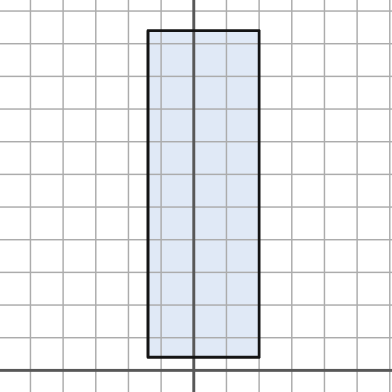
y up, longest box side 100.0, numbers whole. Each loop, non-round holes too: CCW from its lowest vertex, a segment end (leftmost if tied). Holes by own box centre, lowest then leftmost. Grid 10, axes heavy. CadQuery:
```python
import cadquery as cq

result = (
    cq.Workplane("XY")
    .moveTo(-14.0, 4.0)
    .lineTo(20.0, 4.0)
    .lineTo(20.0, 104.0)
    .lineTo(-14.0, 104.0)
    .close()
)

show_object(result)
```